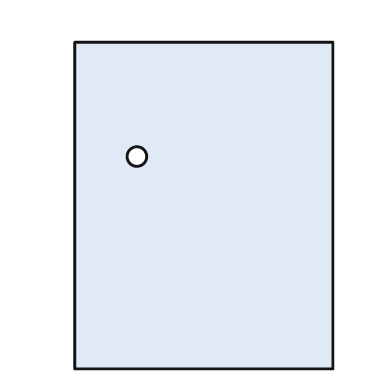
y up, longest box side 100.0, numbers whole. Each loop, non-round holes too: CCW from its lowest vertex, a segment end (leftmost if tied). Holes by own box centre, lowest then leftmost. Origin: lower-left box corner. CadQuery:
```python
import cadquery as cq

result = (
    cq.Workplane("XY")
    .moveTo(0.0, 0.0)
    .lineTo(79.0, 0.0)
    .lineTo(79.0, 100.0)
    .lineTo(0.0, 100.0)
    .close()
    .moveTo(19.0, 65.0)
    .circle(3.0)
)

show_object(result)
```